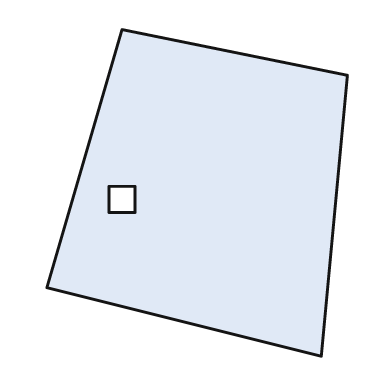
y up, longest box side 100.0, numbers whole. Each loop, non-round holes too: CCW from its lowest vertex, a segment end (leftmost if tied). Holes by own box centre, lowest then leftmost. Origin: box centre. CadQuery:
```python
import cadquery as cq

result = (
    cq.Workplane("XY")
    .moveTo(38.0, -50.0)
    .lineTo(46.0, 36.0)
    .lineTo(-23.0, 50.0)
    .lineTo(-46.0, -29.0)
    .close()
    .moveTo(-27.0, -6.0)
    .lineTo(-19.0, -6.0)
    .lineTo(-19.0, 2.0)
    .lineTo(-27.0, 2.0)
    .close()
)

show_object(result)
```